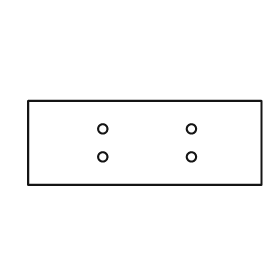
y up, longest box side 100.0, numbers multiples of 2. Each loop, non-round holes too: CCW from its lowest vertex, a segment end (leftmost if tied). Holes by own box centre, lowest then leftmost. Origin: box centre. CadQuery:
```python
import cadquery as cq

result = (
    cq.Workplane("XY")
    .moveTo(-50.0, -18.0)
    .lineTo(50.0, -18.0)
    .lineTo(50.0, 18.0)
    .lineTo(-50.0, 18.0)
    .close()
    .moveTo(-18.0, -6.0)
    .circle(2.0)
    .moveTo(20.0, -6.0)
    .circle(2.0)
    .moveTo(-18.0, 6.0)
    .circle(2.0)
    .moveTo(20.0, 6.0)
    .circle(2.0)
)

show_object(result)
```